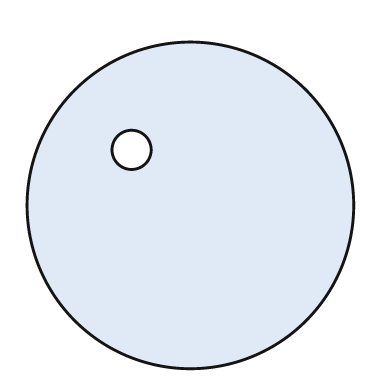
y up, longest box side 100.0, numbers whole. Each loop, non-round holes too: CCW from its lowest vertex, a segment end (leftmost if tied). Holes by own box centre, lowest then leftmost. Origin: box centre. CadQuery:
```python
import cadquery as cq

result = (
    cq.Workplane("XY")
    .moveTo(0.0, 0.0)
    .circle(50.0)
    .moveTo(-18.0, 17.0)
    .circle(6.0)
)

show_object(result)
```